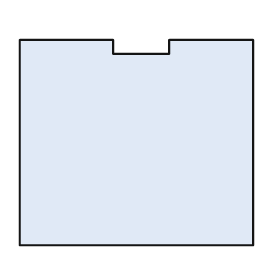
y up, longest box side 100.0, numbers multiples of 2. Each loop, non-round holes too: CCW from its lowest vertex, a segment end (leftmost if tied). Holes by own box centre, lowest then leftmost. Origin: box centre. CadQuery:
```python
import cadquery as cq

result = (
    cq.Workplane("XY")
    .moveTo(-50.0, -44.0)
    .lineTo(50.0, -44.0)
    .lineTo(50.0, 44.0)
    .lineTo(14.0, 44.0)
    .lineTo(14.0, 38.0)
    .lineTo(-10.0, 38.0)
    .lineTo(-10.0, 44.0)
    .lineTo(-50.0, 44.0)
    .close()
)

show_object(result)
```